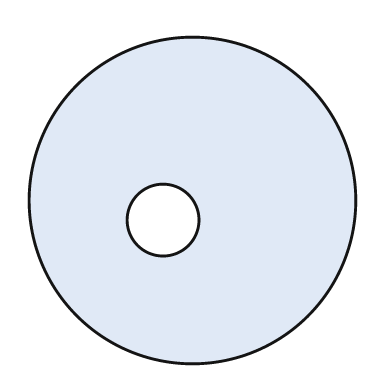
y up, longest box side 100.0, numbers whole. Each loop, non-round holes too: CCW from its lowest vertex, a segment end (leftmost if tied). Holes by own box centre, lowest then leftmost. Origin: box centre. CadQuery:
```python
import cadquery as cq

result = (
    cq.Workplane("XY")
    .moveTo(0.0, 0.0)
    .circle(50.0)
    .moveTo(-9.0, -6.0)
    .circle(11.0)
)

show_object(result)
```